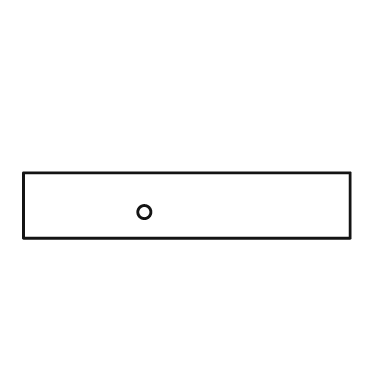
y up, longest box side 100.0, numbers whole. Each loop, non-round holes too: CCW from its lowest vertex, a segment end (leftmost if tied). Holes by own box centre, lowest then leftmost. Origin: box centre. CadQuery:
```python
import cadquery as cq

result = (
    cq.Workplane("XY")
    .moveTo(-50.0, -10.0)
    .lineTo(50.0, -10.0)
    .lineTo(50.0, 10.0)
    .lineTo(-50.0, 10.0)
    .close()
    .moveTo(-13.0, -2.0)
    .circle(2.0)
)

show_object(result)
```